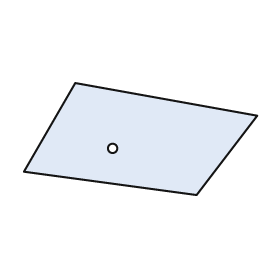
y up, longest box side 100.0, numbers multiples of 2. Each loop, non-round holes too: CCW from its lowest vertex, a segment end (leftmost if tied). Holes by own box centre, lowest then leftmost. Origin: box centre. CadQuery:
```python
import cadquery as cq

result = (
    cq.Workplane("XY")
    .moveTo(24.0, -24.0)
    .lineTo(50.0, 10.0)
    .lineTo(-28.0, 24.0)
    .lineTo(-50.0, -14.0)
    .close()
    .moveTo(-12.0, -4.0)
    .circle(2.0)
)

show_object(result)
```